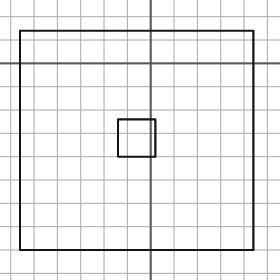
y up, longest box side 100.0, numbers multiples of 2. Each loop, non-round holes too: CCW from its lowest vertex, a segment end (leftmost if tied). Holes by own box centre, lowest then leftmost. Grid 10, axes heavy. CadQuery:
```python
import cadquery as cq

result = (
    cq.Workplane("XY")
    .moveTo(-56.0, -80.0)
    .lineTo(44.0, -80.0)
    .lineTo(44.0, 14.0)
    .lineTo(-56.0, 14.0)
    .close()
    .moveTo(-14.0, -40.0)
    .lineTo(2.0, -40.0)
    .lineTo(2.0, -24.0)
    .lineTo(-14.0, -24.0)
    .close()
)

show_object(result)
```